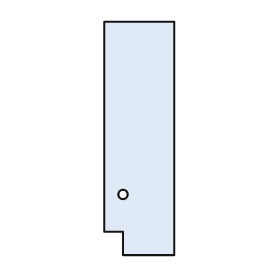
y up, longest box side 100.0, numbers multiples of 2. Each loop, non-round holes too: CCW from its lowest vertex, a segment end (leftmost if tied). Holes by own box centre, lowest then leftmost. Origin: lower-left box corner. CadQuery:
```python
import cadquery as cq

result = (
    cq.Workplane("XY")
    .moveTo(8.0, 0.0)
    .lineTo(30.0, 0.0)
    .lineTo(30.0, 100.0)
    .lineTo(0.0, 100.0)
    .lineTo(0.0, 10.0)
    .lineTo(8.0, 10.0)
    .close()
    .moveTo(8.0, 26.0)
    .circle(2.0)
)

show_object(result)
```